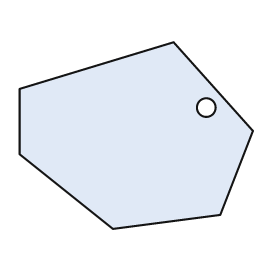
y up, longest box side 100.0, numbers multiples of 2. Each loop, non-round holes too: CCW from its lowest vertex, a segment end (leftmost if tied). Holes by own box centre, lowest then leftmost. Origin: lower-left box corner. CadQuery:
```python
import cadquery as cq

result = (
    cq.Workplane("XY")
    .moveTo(40.0, 0.0)
    .lineTo(86.0, 6.0)
    .lineTo(100.0, 42.0)
    .lineTo(66.0, 80.0)
    .lineTo(0.0, 60.0)
    .lineTo(0.0, 32.0)
    .close()
    .moveTo(80.0, 52.0)
    .circle(4.0)
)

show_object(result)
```